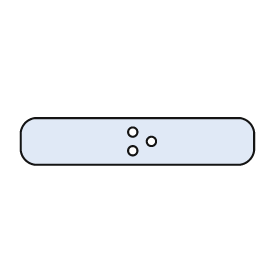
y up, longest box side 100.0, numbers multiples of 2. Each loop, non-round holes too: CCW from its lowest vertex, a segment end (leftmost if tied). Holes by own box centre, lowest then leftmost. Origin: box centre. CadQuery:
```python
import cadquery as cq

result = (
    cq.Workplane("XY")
    .moveTo(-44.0, -10.0)
    .lineTo(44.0, -10.0)
    .threePointArc((48.0, -8.0), (50.0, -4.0))
    .lineTo(50.0, 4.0)
    .threePointArc((48.0, 8.0), (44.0, 10.0))
    .lineTo(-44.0, 10.0)
    .threePointArc((-48.0, 8.0), (-50.0, 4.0))
    .lineTo(-50.0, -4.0)
    .threePointArc((-48.0, -8.0), (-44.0, -10.0))
    .close()
    .moveTo(-2.0, -4.0)
    .circle(2.0)
    .moveTo(6.0, 0.0)
    .circle(2.0)
    .moveTo(-2.0, 4.0)
    .circle(2.0)
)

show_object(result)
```